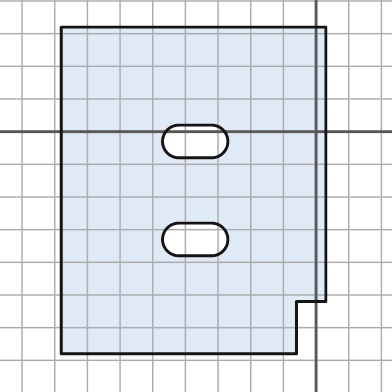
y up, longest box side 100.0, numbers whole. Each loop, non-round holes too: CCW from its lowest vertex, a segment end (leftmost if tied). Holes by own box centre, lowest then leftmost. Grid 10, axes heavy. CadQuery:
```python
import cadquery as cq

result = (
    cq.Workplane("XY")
    .moveTo(-78.0, -68.0)
    .lineTo(-6.0, -68.0)
    .lineTo(-6.0, -52.0)
    .lineTo(3.0, -52.0)
    .lineTo(3.0, 32.0)
    .lineTo(-78.0, 32.0)
    .close()
    .moveTo(-42.0, -38.0)
    .lineTo(-32.0, -38.0)
    .threePointArc((-27.0, -33.0), (-32.0, -28.0))
    .lineTo(-42.0, -28.0)
    .threePointArc((-47.0, -33.0), (-42.0, -38.0))
    .close()
    .moveTo(-42.0, -8.0)
    .lineTo(-32.0, -8.0)
    .threePointArc((-27.0, -3.0), (-32.0, 2.0))
    .lineTo(-42.0, 2.0)
    .threePointArc((-47.0, -3.0), (-42.0, -8.0))
    .close()
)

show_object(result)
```